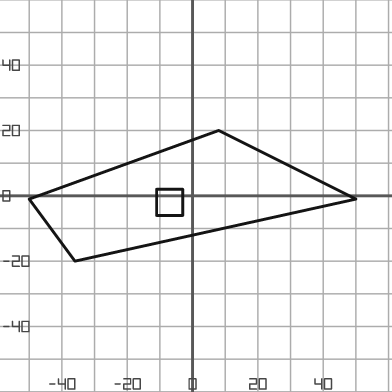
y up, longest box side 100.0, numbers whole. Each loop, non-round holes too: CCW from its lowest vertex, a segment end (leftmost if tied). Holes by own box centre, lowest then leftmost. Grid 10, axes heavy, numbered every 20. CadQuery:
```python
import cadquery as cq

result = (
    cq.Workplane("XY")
    .moveTo(-36.0, -20.0)
    .lineTo(50.0, -1.0)
    .lineTo(8.0, 20.0)
    .lineTo(-50.0, -1.0)
    .close()
    .moveTo(-11.0, -6.0)
    .lineTo(-3.0, -6.0)
    .lineTo(-3.0, 2.0)
    .lineTo(-11.0, 2.0)
    .close()
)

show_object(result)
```